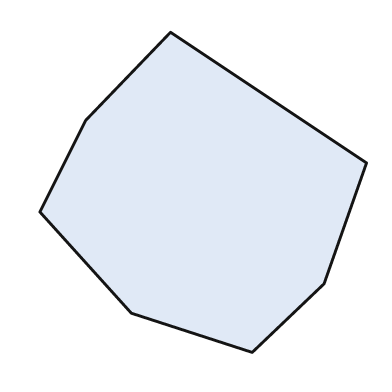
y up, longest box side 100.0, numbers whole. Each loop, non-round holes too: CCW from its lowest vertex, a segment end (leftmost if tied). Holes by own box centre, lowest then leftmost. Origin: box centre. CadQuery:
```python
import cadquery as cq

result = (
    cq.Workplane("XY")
    .moveTo(15.0, -49.0)
    .lineTo(37.0, -28.0)
    .lineTo(50.0, 9.0)
    .lineTo(-10.0, 49.0)
    .lineTo(-36.0, 22.0)
    .lineTo(-50.0, -6.0)
    .lineTo(-22.0, -37.0)
    .close()
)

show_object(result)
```